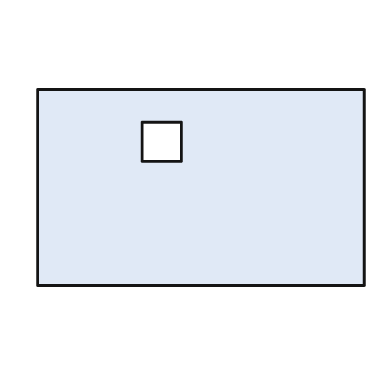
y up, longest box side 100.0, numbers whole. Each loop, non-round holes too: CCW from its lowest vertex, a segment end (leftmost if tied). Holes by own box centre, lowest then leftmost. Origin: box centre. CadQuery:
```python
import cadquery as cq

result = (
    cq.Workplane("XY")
    .moveTo(-50.0, -30.0)
    .lineTo(50.0, -30.0)
    .lineTo(50.0, 30.0)
    .lineTo(-50.0, 30.0)
    .close()
    .moveTo(-18.0, 8.0)
    .lineTo(-6.0, 8.0)
    .lineTo(-6.0, 20.0)
    .lineTo(-18.0, 20.0)
    .close()
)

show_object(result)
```